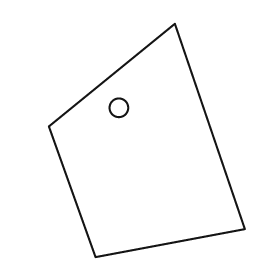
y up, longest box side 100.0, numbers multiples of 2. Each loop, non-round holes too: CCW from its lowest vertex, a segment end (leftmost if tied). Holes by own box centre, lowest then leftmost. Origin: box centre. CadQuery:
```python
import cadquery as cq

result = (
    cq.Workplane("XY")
    .moveTo(-22.0, -50.0)
    .lineTo(42.0, -38.0)
    .lineTo(12.0, 50.0)
    .lineTo(-42.0, 6.0)
    .close()
    .moveTo(-12.0, 14.0)
    .circle(4.0)
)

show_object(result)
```